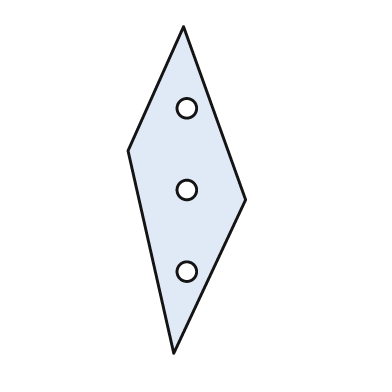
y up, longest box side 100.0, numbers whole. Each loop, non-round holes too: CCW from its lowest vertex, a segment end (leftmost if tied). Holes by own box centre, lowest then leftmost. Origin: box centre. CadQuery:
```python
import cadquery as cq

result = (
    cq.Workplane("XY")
    .moveTo(-4.0, -50.0)
    .lineTo(18.0, -3.0)
    .lineTo(-1.0, 50.0)
    .lineTo(-18.0, 12.0)
    .close()
    .moveTo(0.0, -25.0)
    .circle(3.0)
    .moveTo(0.0, 0.0)
    .circle(3.0)
    .moveTo(0.0, 25.0)
    .circle(3.0)
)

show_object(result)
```